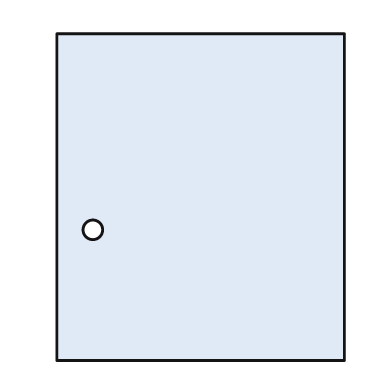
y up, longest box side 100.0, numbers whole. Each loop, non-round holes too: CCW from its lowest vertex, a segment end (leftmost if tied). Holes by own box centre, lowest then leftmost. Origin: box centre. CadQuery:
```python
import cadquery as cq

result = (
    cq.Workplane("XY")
    .moveTo(-44.0, -50.0)
    .lineTo(44.0, -50.0)
    .lineTo(44.0, 50.0)
    .lineTo(-44.0, 50.0)
    .close()
    .moveTo(-33.0, -10.0)
    .circle(3.0)
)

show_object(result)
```